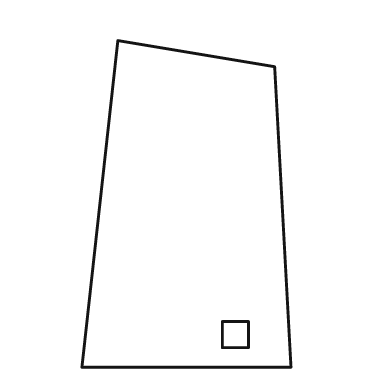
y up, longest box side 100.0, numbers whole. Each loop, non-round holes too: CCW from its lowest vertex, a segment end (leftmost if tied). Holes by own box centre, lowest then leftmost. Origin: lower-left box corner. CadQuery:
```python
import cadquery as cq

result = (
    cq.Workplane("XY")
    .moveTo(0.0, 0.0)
    .lineTo(64.0, 0.0)
    .lineTo(59.0, 92.0)
    .lineTo(11.0, 100.0)
    .close()
    .moveTo(43.0, 6.0)
    .lineTo(51.0, 6.0)
    .lineTo(51.0, 14.0)
    .lineTo(43.0, 14.0)
    .close()
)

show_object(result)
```